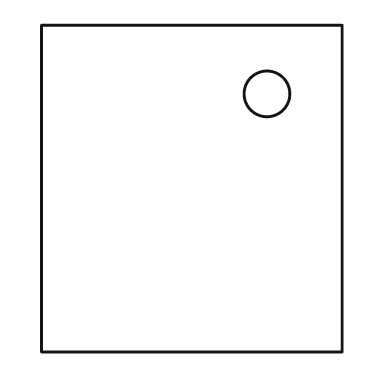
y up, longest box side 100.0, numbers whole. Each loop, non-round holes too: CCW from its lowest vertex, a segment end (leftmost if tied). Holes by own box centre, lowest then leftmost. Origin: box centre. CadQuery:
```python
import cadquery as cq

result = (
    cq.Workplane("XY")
    .moveTo(-46.0, -50.0)
    .lineTo(46.0, -50.0)
    .lineTo(46.0, 50.0)
    .lineTo(-46.0, 50.0)
    .close()
    .moveTo(23.0, 29.0)
    .circle(7.0)
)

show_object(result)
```